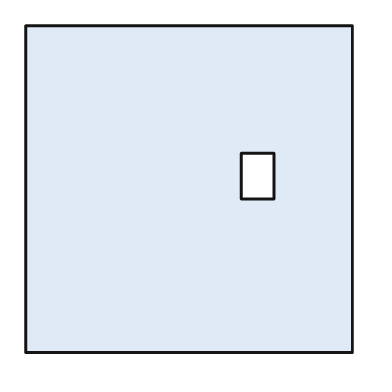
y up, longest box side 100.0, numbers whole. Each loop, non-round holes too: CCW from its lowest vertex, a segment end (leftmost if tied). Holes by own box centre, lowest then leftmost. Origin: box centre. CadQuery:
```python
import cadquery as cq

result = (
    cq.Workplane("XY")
    .moveTo(-50.0, -50.0)
    .lineTo(50.0, -50.0)
    .lineTo(50.0, 50.0)
    .lineTo(-50.0, 50.0)
    .close()
    .moveTo(16.0, -3.0)
    .lineTo(26.0, -3.0)
    .lineTo(26.0, 11.0)
    .lineTo(16.0, 11.0)
    .close()
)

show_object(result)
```